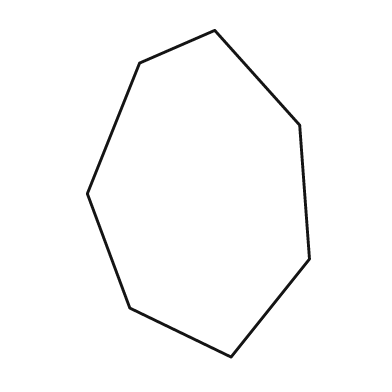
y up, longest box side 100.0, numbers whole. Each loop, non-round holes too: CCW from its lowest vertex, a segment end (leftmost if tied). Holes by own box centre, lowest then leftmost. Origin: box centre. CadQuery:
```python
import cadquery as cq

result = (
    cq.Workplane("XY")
    .moveTo(10.0, -50.0)
    .lineTo(34.0, -20.0)
    .lineTo(31.0, 21.0)
    .lineTo(5.0, 50.0)
    .lineTo(-18.0, 40.0)
    .lineTo(-34.0, 0.0)
    .lineTo(-21.0, -35.0)
    .close()
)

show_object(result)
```